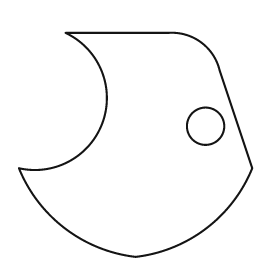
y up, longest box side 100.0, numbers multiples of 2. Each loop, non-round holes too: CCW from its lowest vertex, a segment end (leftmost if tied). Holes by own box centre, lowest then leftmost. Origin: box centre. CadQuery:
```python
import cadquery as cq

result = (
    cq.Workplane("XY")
    .moveTo(0.0, -48.0)
    .threePointArc((30.0, -36.0), (50.0, -10.0))
    .lineTo(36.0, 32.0)
    .threePointArc((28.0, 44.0), (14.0, 48.0))
    .lineTo(-30.0, 48.0)
    .threePointArc((-14.0, 10.0), (-50.0, -10.0))
    .threePointArc((-30.0, -36.0), (0.0, -48.0))
    .close()
    .moveTo(30.0, 8.0)
    .circle(8.0)
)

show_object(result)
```